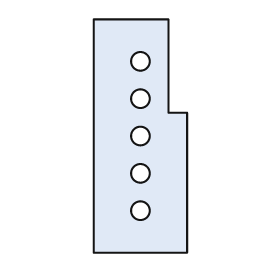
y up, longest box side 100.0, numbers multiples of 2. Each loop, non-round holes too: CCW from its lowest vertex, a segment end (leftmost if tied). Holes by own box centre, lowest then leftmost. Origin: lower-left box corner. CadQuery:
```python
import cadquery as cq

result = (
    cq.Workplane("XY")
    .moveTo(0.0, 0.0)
    .lineTo(40.0, 0.0)
    .lineTo(40.0, 60.0)
    .lineTo(32.0, 60.0)
    .lineTo(32.0, 100.0)
    .lineTo(0.0, 100.0)
    .close()
    .moveTo(20.0, 18.0)
    .circle(4.0)
    .moveTo(20.0, 34.0)
    .circle(4.0)
    .moveTo(20.0, 50.0)
    .circle(4.0)
    .moveTo(20.0, 66.0)
    .circle(4.0)
    .moveTo(20.0, 82.0)
    .circle(4.0)
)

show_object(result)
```